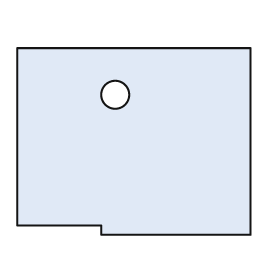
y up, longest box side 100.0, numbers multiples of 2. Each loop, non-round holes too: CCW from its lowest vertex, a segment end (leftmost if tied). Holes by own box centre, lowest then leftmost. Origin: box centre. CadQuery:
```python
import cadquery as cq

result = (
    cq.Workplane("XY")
    .moveTo(-14.0, -40.0)
    .lineTo(50.0, -40.0)
    .lineTo(50.0, 40.0)
    .lineTo(-50.0, 40.0)
    .lineTo(-50.0, -36.0)
    .lineTo(-14.0, -36.0)
    .close()
    .moveTo(-8.0, 20.0)
    .circle(6.0)
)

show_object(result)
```